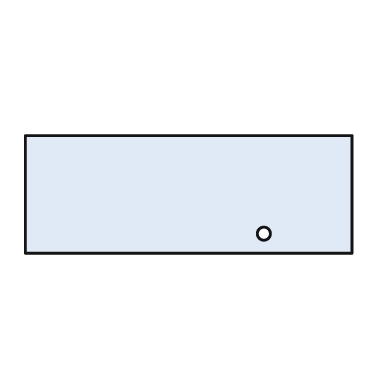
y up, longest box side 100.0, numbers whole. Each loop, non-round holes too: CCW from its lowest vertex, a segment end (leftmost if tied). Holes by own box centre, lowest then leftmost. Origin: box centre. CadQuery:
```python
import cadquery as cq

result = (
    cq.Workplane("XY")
    .moveTo(-50.0, -18.0)
    .lineTo(50.0, -18.0)
    .lineTo(50.0, 18.0)
    .lineTo(-50.0, 18.0)
    .close()
    .moveTo(23.0, -12.0)
    .circle(2.0)
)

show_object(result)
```